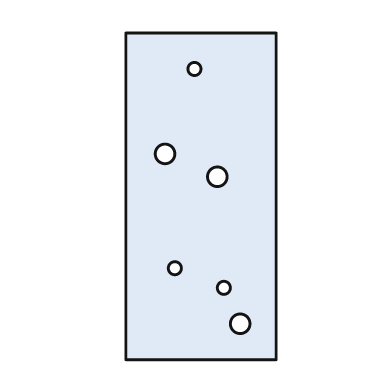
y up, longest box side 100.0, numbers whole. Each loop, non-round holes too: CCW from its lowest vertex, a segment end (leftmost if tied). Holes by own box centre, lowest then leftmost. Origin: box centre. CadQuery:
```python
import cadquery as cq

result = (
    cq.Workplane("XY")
    .moveTo(-23.0, -50.0)
    .lineTo(23.0, -50.0)
    .lineTo(23.0, 50.0)
    .lineTo(-23.0, 50.0)
    .close()
    .moveTo(12.0, -39.0)
    .circle(3.0)
    .moveTo(7.0, -28.0)
    .circle(2.0)
    .moveTo(-8.0, -22.0)
    .circle(2.0)
    .moveTo(5.0, 6.0)
    .circle(3.0)
    .moveTo(-11.0, 13.0)
    .circle(3.0)
    .moveTo(-2.0, 39.0)
    .circle(2.0)
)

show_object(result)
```